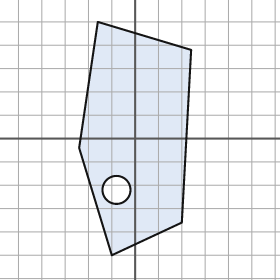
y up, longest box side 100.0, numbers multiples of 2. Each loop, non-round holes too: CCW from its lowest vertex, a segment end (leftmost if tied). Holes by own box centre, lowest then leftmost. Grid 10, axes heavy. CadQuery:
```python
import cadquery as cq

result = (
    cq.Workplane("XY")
    .moveTo(-10.0, -50.0)
    .lineTo(20.0, -36.0)
    .lineTo(24.0, 38.0)
    .lineTo(-16.0, 50.0)
    .lineTo(-24.0, -4.0)
    .close()
    .moveTo(-8.0, -22.0)
    .circle(6.0)
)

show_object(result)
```